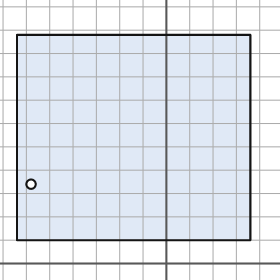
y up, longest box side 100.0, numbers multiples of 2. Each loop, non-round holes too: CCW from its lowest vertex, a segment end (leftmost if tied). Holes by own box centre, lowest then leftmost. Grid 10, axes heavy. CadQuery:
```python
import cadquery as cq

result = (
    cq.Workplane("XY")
    .moveTo(-64.0, 10.0)
    .lineTo(36.0, 10.0)
    .lineTo(36.0, 98.0)
    .lineTo(-64.0, 98.0)
    .close()
    .moveTo(-58.0, 34.0)
    .circle(2.0)
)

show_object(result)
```